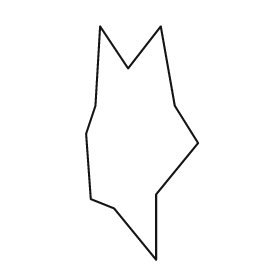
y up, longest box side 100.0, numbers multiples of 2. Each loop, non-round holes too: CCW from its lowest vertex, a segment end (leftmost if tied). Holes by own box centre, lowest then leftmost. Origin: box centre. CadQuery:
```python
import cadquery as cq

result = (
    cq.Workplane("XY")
    .moveTo(6.0, -50.0)
    .lineTo(6.0, -22.0)
    .lineTo(24.0, 0.0)
    .lineTo(14.0, 16.0)
    .lineTo(8.0, 50.0)
    .lineTo(-6.0, 32.0)
    .lineTo(-18.0, 50.0)
    .lineTo(-20.0, 16.0)
    .lineTo(-24.0, 4.0)
    .lineTo(-22.0, -24.0)
    .lineTo(-12.0, -28.0)
    .close()
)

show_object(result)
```